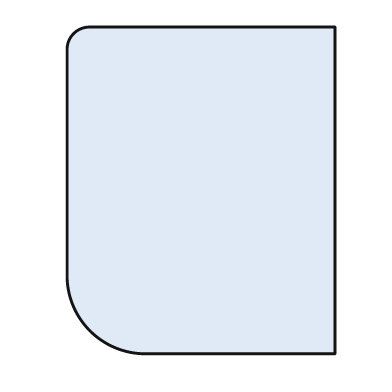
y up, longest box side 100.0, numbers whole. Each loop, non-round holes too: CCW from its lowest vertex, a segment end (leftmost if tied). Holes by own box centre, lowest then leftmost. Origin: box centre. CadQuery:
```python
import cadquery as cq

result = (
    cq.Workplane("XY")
    .moveTo(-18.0, -50.0)
    .lineTo(41.0, -50.0)
    .lineTo(41.0, 50.0)
    .lineTo(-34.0, 50.0)
    .threePointArc((-39.0, 48.0), (-41.0, 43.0))
    .lineTo(-41.0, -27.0)
    .threePointArc((-34.0, -43.0), (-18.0, -50.0))
    .close()
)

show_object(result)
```